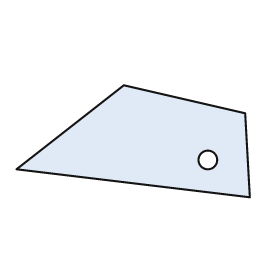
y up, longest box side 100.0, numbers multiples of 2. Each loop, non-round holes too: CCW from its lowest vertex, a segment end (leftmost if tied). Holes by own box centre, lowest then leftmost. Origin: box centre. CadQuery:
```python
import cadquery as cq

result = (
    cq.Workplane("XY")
    .moveTo(50.0, -24.0)
    .lineTo(48.0, 12.0)
    .lineTo(-4.0, 24.0)
    .lineTo(-50.0, -12.0)
    .close()
    .moveTo(32.0, -8.0)
    .circle(4.0)
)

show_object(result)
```